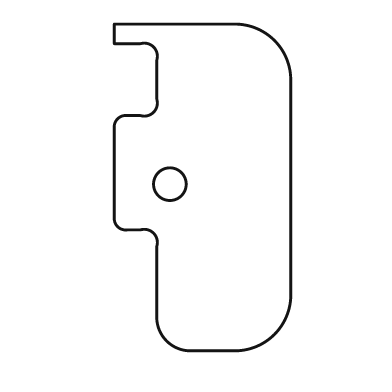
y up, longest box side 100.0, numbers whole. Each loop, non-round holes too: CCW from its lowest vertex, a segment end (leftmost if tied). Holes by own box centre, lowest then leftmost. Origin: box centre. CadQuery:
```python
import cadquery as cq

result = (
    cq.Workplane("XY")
    .moveTo(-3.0, -50.0)
    .lineTo(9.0, -50.0)
    .threePointArc((22.0, -45.0), (27.0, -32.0))
    .lineTo(27.0, 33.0)
    .threePointArc((22.0, 45.0), (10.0, 50.0))
    .lineTo(-27.0, 50.0)
    .lineTo(-27.0, 44.0)
    .lineTo(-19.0, 44.0)
    .threePointArc((-15.0, 43.0), (-14.0, 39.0))
    .lineTo(-14.0, 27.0)
    .threePointArc((-15.0, 23.0), (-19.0, 22.0))
    .lineTo(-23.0, 22.0)
    .threePointArc((-26.0, 21.0), (-27.0, 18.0))
    .lineTo(-27.0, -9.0)
    .threePointArc((-26.0, -12.0), (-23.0, -13.0))
    .lineTo(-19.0, -13.0)
    .threePointArc((-15.0, -14.0), (-14.0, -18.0))
    .lineTo(-14.0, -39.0)
    .threePointArc((-11.0, -47.0), (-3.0, -50.0))
    .close()
    .moveTo(-10.0, 1.0)
    .circle(5.0)
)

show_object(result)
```